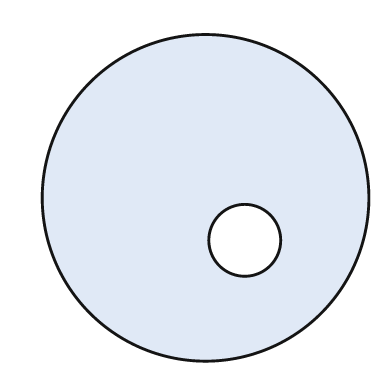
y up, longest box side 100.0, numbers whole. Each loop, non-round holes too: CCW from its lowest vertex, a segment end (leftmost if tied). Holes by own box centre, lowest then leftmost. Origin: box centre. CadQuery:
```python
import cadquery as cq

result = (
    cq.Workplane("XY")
    .moveTo(0.0, 0.0)
    .circle(50.0)
    .moveTo(12.0, -13.0)
    .circle(11.0)
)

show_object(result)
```